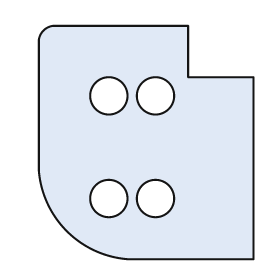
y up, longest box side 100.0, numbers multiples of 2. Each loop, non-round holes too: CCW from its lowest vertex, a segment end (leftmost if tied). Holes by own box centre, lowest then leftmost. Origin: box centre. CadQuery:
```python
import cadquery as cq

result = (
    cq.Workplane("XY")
    .moveTo(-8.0, -50.0)
    .lineTo(46.0, -50.0)
    .lineTo(46.0, 28.0)
    .lineTo(18.0, 28.0)
    .lineTo(18.0, 50.0)
    .lineTo(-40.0, 50.0)
    .threePointArc((-44.0, 48.0), (-46.0, 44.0))
    .lineTo(-46.0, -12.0)
    .threePointArc((-34.0, -38.0), (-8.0, -50.0))
    .close()
    .moveTo(-16.0, -24.0)
    .circle(8.0)
    .moveTo(4.0, -24.0)
    .circle(8.0)
    .moveTo(-16.0, 20.0)
    .circle(8.0)
    .moveTo(4.0, 20.0)
    .circle(8.0)
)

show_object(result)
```